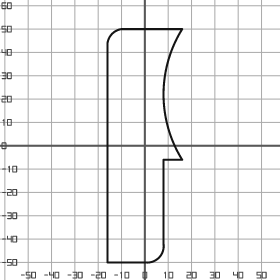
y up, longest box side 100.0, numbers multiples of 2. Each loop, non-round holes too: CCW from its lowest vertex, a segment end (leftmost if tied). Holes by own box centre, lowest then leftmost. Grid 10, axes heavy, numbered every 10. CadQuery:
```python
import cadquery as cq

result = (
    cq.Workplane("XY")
    .moveTo(-16.0, -50.0)
    .lineTo(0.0, -50.0)
    .threePointArc((6.0, -48.0), (8.0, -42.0))
    .lineTo(8.0, -6.0)
    .lineTo(16.0, -6.0)
    .threePointArc((8.0, 22.0), (16.0, 50.0))
    .lineTo(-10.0, 50.0)
    .threePointArc((-14.0, 48.0), (-16.0, 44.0))
    .close()
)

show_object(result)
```